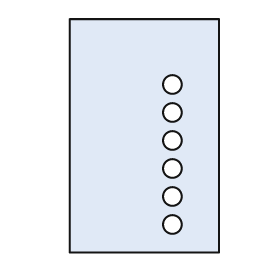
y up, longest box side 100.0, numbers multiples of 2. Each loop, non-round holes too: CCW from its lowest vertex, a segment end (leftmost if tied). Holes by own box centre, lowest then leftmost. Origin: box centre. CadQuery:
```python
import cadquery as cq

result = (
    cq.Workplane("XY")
    .moveTo(-32.0, -50.0)
    .lineTo(32.0, -50.0)
    .lineTo(32.0, 50.0)
    .lineTo(-32.0, 50.0)
    .close()
    .moveTo(12.0, -38.0)
    .circle(4.0)
    .moveTo(12.0, -26.0)
    .circle(4.0)
    .moveTo(12.0, -14.0)
    .circle(4.0)
    .moveTo(12.0, -2.0)
    .circle(4.0)
    .moveTo(12.0, 10.0)
    .circle(4.0)
    .moveTo(12.0, 22.0)
    .circle(4.0)
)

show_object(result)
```